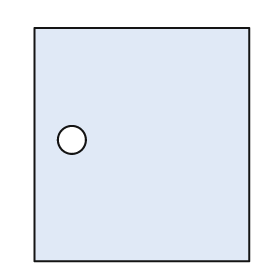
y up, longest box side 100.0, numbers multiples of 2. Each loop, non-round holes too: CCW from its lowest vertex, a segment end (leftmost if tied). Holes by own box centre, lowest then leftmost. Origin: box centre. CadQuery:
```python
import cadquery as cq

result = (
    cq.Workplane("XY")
    .moveTo(-46.0, -50.0)
    .lineTo(46.0, -50.0)
    .lineTo(46.0, 50.0)
    .lineTo(-46.0, 50.0)
    .close()
    .moveTo(-30.0, 2.0)
    .circle(6.0)
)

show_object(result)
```